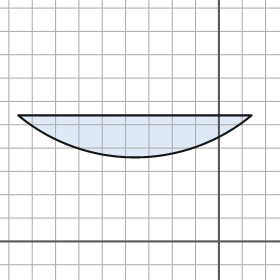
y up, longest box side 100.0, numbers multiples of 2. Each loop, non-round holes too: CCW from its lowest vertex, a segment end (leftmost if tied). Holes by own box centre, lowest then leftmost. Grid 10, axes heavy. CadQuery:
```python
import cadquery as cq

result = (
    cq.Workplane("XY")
    .moveTo(-86.0, 54.0)
    .threePointArc((-36.0, 36.0), (14.0, 54.0))
    .close()
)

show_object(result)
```